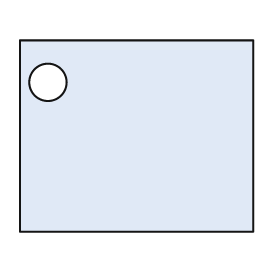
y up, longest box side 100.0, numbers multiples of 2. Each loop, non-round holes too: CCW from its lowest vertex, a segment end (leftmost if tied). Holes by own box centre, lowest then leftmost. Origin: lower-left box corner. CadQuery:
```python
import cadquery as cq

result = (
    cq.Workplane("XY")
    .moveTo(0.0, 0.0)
    .lineTo(100.0, 0.0)
    .lineTo(100.0, 82.0)
    .lineTo(0.0, 82.0)
    .close()
    .moveTo(12.0, 64.0)
    .circle(8.0)
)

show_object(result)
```